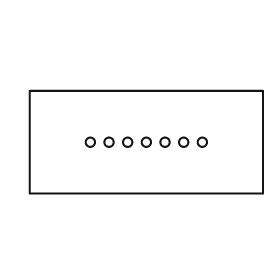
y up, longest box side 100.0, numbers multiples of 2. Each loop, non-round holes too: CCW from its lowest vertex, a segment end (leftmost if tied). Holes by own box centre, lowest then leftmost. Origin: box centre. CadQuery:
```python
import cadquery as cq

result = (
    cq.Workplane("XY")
    .moveTo(-50.0, -22.0)
    .lineTo(50.0, -22.0)
    .lineTo(50.0, 22.0)
    .lineTo(-50.0, 22.0)
    .close()
    .moveTo(-24.0, 0.0)
    .circle(2.0)
    .moveTo(-16.0, 0.0)
    .circle(2.0)
    .moveTo(-8.0, 0.0)
    .circle(2.0)
    .moveTo(0.0, 0.0)
    .circle(2.0)
    .moveTo(8.0, 0.0)
    .circle(2.0)
    .moveTo(16.0, 0.0)
    .circle(2.0)
    .moveTo(24.0, 0.0)
    .circle(2.0)
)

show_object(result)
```